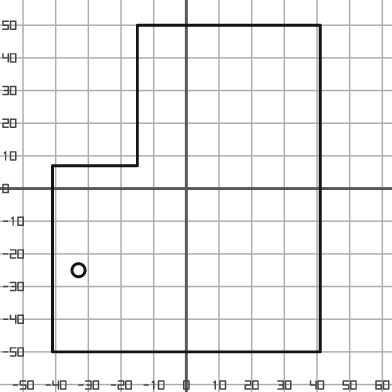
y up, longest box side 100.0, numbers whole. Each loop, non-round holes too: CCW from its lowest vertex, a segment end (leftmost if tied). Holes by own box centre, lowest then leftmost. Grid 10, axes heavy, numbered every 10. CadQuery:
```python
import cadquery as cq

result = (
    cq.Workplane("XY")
    .moveTo(-41.0, -50.0)
    .lineTo(41.0, -50.0)
    .lineTo(41.0, 50.0)
    .lineTo(-15.0, 50.0)
    .lineTo(-15.0, 7.0)
    .lineTo(-41.0, 7.0)
    .close()
    .moveTo(-33.0, -25.0)
    .circle(2.0)
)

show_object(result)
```